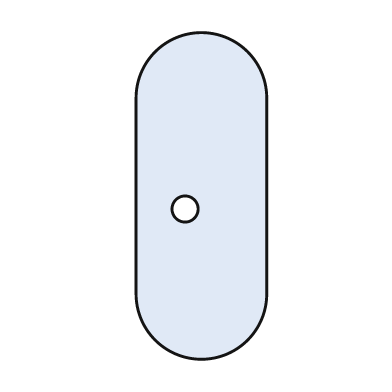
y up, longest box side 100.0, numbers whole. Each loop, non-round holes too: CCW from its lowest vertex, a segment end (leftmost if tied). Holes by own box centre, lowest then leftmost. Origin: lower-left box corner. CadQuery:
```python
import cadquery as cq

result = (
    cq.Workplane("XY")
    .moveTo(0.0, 20.0)
    .threePointArc((20.0, 0.0), (40.0, 20.0))
    .lineTo(40.0, 80.0)
    .threePointArc((20.0, 100.0), (0.0, 80.0))
    .close()
    .moveTo(15.0, 46.0)
    .circle(4.0)
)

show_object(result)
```